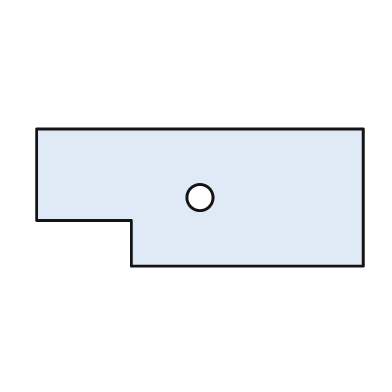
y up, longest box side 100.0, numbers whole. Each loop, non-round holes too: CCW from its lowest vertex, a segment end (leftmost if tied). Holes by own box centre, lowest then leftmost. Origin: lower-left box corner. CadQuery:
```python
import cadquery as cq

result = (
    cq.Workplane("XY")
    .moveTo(29.0, 0.0)
    .lineTo(100.0, 0.0)
    .lineTo(100.0, 42.0)
    .lineTo(0.0, 42.0)
    .lineTo(0.0, 14.0)
    .lineTo(29.0, 14.0)
    .close()
    .moveTo(50.0, 21.0)
    .circle(4.0)
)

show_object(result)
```